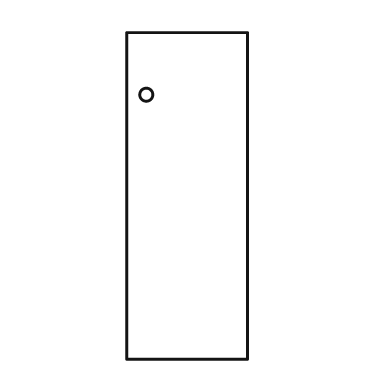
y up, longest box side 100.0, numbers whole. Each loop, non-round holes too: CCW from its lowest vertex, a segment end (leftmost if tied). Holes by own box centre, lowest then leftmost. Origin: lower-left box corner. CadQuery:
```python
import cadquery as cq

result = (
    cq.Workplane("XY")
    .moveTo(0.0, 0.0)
    .lineTo(37.0, 0.0)
    .lineTo(37.0, 100.0)
    .lineTo(0.0, 100.0)
    .close()
    .moveTo(6.0, 81.0)
    .circle(2.0)
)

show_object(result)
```